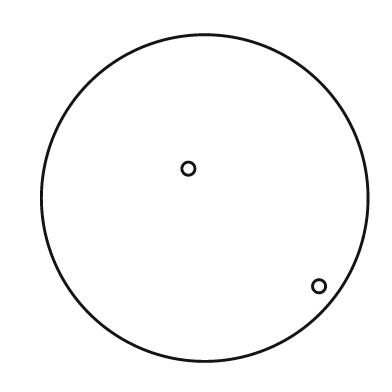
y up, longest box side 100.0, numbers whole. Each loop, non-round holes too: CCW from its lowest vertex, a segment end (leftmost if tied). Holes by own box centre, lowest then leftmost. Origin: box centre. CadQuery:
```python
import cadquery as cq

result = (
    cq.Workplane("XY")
    .moveTo(0.0, 0.0)
    .circle(50.0)
    .moveTo(35.0, -27.0)
    .circle(2.0)
    .moveTo(-5.0, 9.0)
    .circle(2.0)
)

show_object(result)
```